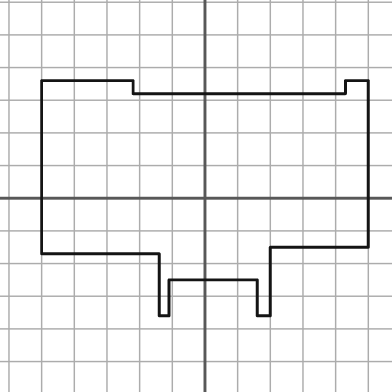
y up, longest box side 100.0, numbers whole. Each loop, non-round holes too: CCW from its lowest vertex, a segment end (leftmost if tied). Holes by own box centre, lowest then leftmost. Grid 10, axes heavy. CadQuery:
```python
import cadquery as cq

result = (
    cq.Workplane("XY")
    .moveTo(-14.0, -36.0)
    .lineTo(-11.0, -36.0)
    .lineTo(-11.0, -25.0)
    .lineTo(16.0, -25.0)
    .lineTo(16.0, -36.0)
    .lineTo(20.0, -36.0)
    .lineTo(20.0, -15.0)
    .lineTo(50.0, -15.0)
    .lineTo(50.0, 36.0)
    .lineTo(43.0, 36.0)
    .lineTo(43.0, 32.0)
    .lineTo(-22.0, 32.0)
    .lineTo(-22.0, 36.0)
    .lineTo(-50.0, 36.0)
    .lineTo(-50.0, -17.0)
    .lineTo(-14.0, -17.0)
    .close()
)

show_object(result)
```